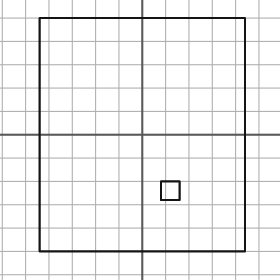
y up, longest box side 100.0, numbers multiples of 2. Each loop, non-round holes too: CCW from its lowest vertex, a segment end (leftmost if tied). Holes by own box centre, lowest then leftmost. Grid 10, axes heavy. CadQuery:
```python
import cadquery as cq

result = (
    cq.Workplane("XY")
    .moveTo(-44.0, -50.0)
    .lineTo(44.0, -50.0)
    .lineTo(44.0, 50.0)
    .lineTo(-44.0, 50.0)
    .close()
    .moveTo(8.0, -28.0)
    .lineTo(16.0, -28.0)
    .lineTo(16.0, -20.0)
    .lineTo(8.0, -20.0)
    .close()
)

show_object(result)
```